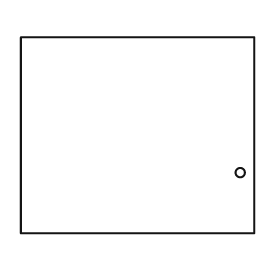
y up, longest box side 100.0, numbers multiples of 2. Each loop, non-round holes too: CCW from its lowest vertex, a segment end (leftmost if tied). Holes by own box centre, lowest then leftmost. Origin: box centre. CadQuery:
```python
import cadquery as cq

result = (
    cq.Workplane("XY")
    .moveTo(-50.0, -42.0)
    .lineTo(50.0, -42.0)
    .lineTo(50.0, 42.0)
    .lineTo(-50.0, 42.0)
    .close()
    .moveTo(44.0, -16.0)
    .circle(2.0)
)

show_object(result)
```